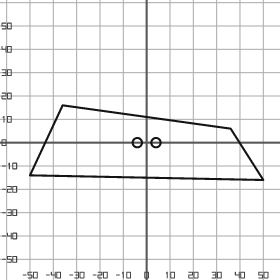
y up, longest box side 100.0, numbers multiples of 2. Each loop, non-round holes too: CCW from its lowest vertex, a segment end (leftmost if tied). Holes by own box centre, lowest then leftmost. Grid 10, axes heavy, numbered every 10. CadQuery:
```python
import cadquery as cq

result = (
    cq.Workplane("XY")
    .moveTo(50.0, -16.0)
    .lineTo(36.0, 6.0)
    .lineTo(-36.0, 16.0)
    .lineTo(-50.0, -14.0)
    .close()
    .moveTo(-4.0, 0.0)
    .circle(2.0)
    .moveTo(4.0, 0.0)
    .circle(2.0)
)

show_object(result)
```